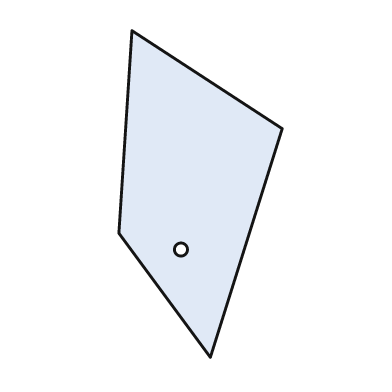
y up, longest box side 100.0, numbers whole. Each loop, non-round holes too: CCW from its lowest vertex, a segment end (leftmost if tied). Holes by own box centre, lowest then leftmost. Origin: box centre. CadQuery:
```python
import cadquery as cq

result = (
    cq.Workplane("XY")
    .moveTo(3.0, -50.0)
    .lineTo(25.0, 20.0)
    .lineTo(-21.0, 50.0)
    .lineTo(-25.0, -12.0)
    .close()
    .moveTo(-6.0, -17.0)
    .circle(2.0)
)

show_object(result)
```